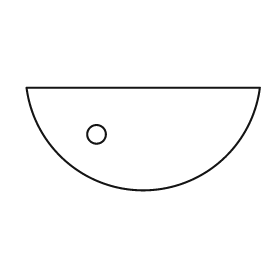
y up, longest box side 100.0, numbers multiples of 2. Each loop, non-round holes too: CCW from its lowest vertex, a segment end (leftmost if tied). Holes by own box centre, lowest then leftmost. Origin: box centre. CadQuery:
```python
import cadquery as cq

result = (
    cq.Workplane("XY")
    .moveTo(-50.0, 22.0)
    .threePointArc((0.0, -22.0), (50.0, 22.0))
    .close()
    .moveTo(-20.0, 2.0)
    .circle(4.0)
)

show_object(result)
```